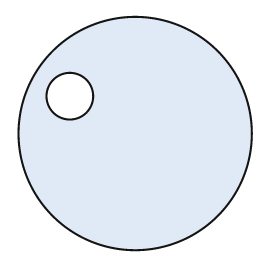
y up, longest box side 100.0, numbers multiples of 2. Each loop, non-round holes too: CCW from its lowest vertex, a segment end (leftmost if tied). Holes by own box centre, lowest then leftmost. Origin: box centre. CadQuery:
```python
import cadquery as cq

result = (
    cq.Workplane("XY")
    .moveTo(0.0, 0.0)
    .circle(50.0)
    .moveTo(-28.0, 16.0)
    .circle(10.0)
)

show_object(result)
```